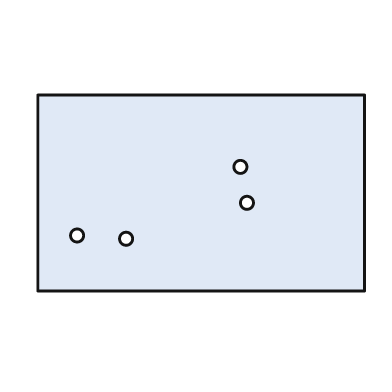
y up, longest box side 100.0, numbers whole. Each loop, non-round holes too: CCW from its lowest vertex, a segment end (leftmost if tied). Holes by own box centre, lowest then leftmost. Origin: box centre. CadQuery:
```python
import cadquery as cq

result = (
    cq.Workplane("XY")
    .moveTo(-50.0, -30.0)
    .lineTo(50.0, -30.0)
    .lineTo(50.0, 30.0)
    .lineTo(-50.0, 30.0)
    .close()
    .moveTo(-23.0, -14.0)
    .circle(2.0)
    .moveTo(-38.0, -13.0)
    .circle(2.0)
    .moveTo(14.0, -3.0)
    .circle(2.0)
    .moveTo(12.0, 8.0)
    .circle(2.0)
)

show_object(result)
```